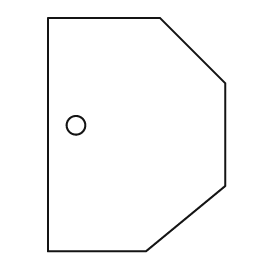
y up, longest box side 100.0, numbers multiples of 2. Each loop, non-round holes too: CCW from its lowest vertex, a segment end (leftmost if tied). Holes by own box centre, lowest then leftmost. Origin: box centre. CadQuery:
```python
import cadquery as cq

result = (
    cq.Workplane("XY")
    .moveTo(-38.0, -50.0)
    .lineTo(4.0, -50.0)
    .lineTo(38.0, -22.0)
    .lineTo(38.0, 22.0)
    .lineTo(10.0, 50.0)
    .lineTo(-38.0, 50.0)
    .close()
    .moveTo(-26.0, 4.0)
    .circle(4.0)
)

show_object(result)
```